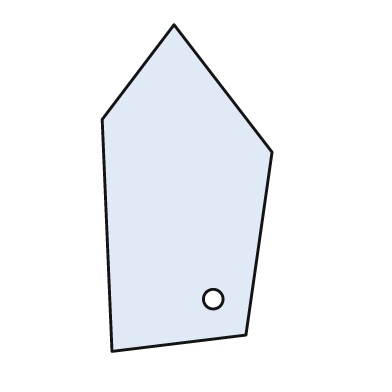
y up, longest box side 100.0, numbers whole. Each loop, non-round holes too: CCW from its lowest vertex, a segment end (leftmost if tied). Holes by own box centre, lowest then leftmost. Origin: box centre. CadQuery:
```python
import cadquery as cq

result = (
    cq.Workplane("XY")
    .moveTo(-23.0, -50.0)
    .lineTo(18.0, -45.0)
    .lineTo(26.0, 11.0)
    .lineTo(-4.0, 50.0)
    .lineTo(-26.0, 21.0)
    .close()
    .moveTo(8.0, -34.0)
    .circle(3.0)
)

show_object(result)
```